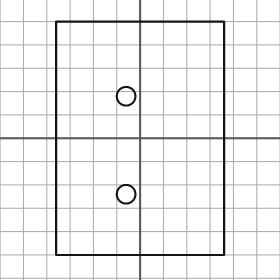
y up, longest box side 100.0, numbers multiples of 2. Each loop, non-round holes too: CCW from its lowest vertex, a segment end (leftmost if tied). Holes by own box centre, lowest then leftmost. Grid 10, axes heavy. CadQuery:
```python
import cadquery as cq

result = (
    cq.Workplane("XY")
    .moveTo(-36.0, -50.0)
    .lineTo(36.0, -50.0)
    .lineTo(36.0, 50.0)
    .lineTo(-36.0, 50.0)
    .close()
    .moveTo(-6.0, -24.0)
    .circle(4.0)
    .moveTo(-6.0, 18.0)
    .circle(4.0)
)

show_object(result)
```